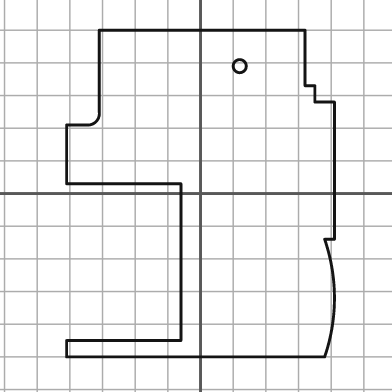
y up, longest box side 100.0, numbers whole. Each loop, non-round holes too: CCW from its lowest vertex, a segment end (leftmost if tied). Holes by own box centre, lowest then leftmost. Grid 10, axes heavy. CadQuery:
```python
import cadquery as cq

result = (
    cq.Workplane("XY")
    .moveTo(-41.0, -50.0)
    .lineTo(38.0, -50.0)
    .threePointArc((41.0, -32.0), (38.0, -14.0))
    .lineTo(41.0, -14.0)
    .lineTo(41.0, 28.0)
    .lineTo(35.0, 28.0)
    .lineTo(35.0, 33.0)
    .lineTo(32.0, 33.0)
    .lineTo(32.0, 50.0)
    .lineTo(-31.0, 50.0)
    .lineTo(-31.0, 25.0)
    .threePointArc((-32.0, 22.0), (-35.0, 21.0))
    .lineTo(-41.0, 21.0)
    .lineTo(-41.0, 3.0)
    .lineTo(-6.0, 3.0)
    .lineTo(-6.0, -45.0)
    .lineTo(-41.0, -45.0)
    .close()
    .moveTo(12.0, 39.0)
    .circle(2.0)
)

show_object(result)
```